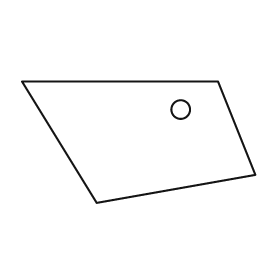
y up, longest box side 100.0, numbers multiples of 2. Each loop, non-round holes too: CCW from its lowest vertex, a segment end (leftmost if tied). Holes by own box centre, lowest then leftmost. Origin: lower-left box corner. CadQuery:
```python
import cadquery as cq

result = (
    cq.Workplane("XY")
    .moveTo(32.0, 0.0)
    .lineTo(100.0, 12.0)
    .lineTo(84.0, 52.0)
    .lineTo(0.0, 52.0)
    .close()
    .moveTo(68.0, 40.0)
    .circle(4.0)
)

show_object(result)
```